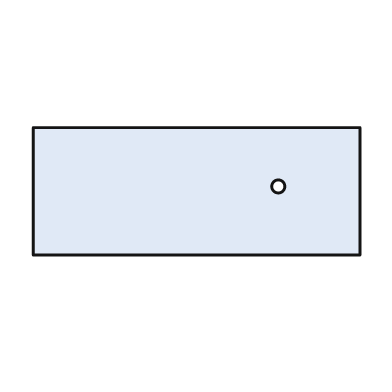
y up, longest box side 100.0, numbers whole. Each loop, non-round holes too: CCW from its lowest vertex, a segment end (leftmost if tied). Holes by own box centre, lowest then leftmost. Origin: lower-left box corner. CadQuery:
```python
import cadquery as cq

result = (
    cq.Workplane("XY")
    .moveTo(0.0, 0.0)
    .lineTo(100.0, 0.0)
    .lineTo(100.0, 39.0)
    .lineTo(0.0, 39.0)
    .close()
    .moveTo(75.0, 21.0)
    .circle(2.0)
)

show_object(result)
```